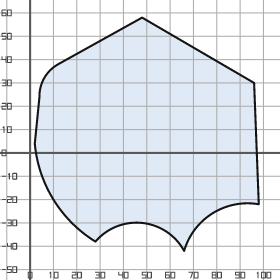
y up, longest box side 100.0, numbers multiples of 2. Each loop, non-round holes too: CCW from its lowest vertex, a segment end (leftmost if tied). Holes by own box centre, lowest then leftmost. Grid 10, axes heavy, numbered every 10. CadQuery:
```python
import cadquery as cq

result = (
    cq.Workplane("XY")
    .moveTo(66.0, -42.0)
    .threePointArc((78.0, -26.0), (98.0, -22.0))
    .lineTo(96.0, 30.0)
    .lineTo(48.0, 58.0)
    .lineTo(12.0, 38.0)
    .threePointArc((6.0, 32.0), (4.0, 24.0))
    .lineTo(2.0, 4.0)
    .threePointArc((10.0, -20.0), (28.0, -38.0))
    .threePointArc((48.0, -30.0), (66.0, -42.0))
    .close()
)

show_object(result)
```